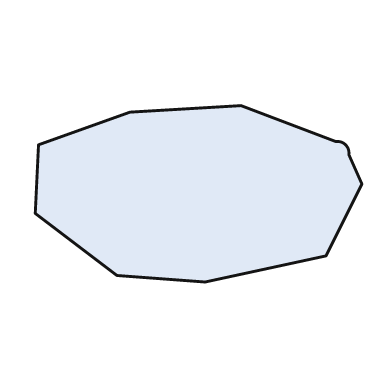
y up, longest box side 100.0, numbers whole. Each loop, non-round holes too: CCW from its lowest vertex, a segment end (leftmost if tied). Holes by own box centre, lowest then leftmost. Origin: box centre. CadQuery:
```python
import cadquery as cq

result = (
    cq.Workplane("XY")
    .moveTo(2.0, -27.0)
    .lineTo(39.0, -19.0)
    .lineTo(50.0, 3.0)
    .lineTo(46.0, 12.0)
    .threePointArc((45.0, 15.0), (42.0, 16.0))
    .lineTo(13.0, 27.0)
    .lineTo(-21.0, 25.0)
    .lineTo(-49.0, 15.0)
    .lineTo(-50.0, -6.0)
    .lineTo(-25.0, -25.0)
    .close()
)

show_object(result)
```